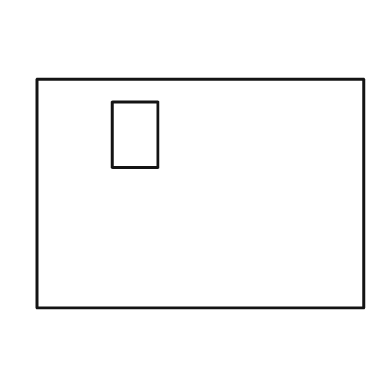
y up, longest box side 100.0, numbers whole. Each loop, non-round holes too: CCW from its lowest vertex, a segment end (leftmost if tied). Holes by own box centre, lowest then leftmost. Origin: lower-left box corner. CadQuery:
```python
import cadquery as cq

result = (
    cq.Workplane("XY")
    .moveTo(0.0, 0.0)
    .lineTo(100.0, 0.0)
    .lineTo(100.0, 70.0)
    .lineTo(0.0, 70.0)
    .close()
    .moveTo(23.0, 43.0)
    .lineTo(37.0, 43.0)
    .lineTo(37.0, 63.0)
    .lineTo(23.0, 63.0)
    .close()
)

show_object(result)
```